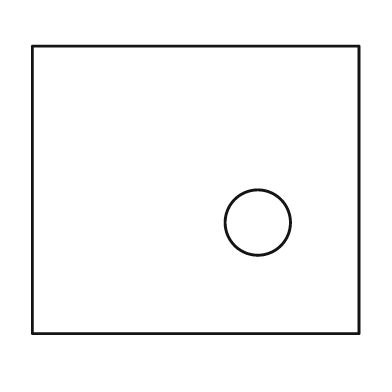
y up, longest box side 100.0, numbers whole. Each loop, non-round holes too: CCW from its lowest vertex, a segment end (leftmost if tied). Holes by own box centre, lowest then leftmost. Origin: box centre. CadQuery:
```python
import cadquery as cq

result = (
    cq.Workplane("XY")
    .moveTo(-50.0, -44.0)
    .lineTo(50.0, -44.0)
    .lineTo(50.0, 44.0)
    .lineTo(-50.0, 44.0)
    .close()
    .moveTo(19.0, -10.0)
    .circle(10.0)
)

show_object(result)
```